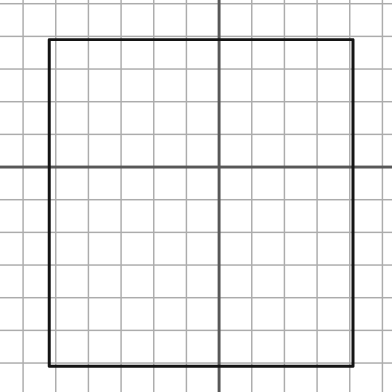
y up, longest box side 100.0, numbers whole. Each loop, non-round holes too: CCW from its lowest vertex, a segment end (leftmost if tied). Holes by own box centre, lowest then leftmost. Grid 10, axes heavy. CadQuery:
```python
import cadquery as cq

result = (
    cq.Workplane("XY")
    .moveTo(-52.0, -61.0)
    .lineTo(41.0, -61.0)
    .lineTo(41.0, 39.0)
    .lineTo(-52.0, 39.0)
    .close()
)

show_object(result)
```